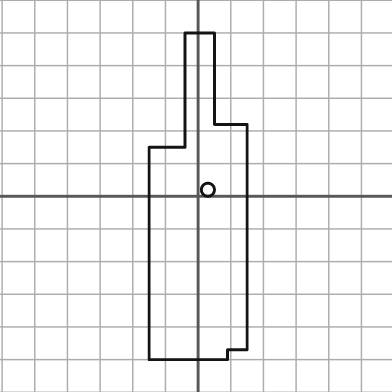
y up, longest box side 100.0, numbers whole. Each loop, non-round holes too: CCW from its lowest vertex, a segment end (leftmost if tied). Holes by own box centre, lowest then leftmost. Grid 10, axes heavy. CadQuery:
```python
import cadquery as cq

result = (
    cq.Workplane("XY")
    .moveTo(-15.0, -50.0)
    .lineTo(9.0, -50.0)
    .lineTo(9.0, -47.0)
    .lineTo(15.0, -47.0)
    .lineTo(15.0, 22.0)
    .lineTo(5.0, 22.0)
    .lineTo(5.0, 50.0)
    .lineTo(-4.0, 50.0)
    .lineTo(-4.0, 15.0)
    .lineTo(-15.0, 15.0)
    .close()
    .moveTo(3.0, 2.0)
    .circle(2.0)
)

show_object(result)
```